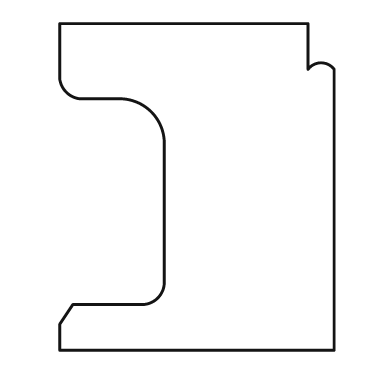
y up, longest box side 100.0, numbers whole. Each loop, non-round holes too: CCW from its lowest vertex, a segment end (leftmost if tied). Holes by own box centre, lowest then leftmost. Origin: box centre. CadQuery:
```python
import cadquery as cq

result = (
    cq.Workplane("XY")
    .moveTo(-42.0, -50.0)
    .lineTo(42.0, -50.0)
    .lineTo(42.0, 36.0)
    .threePointArc((38.0, 38.0), (34.0, 36.0))
    .lineTo(34.0, 50.0)
    .lineTo(-42.0, 50.0)
    .lineTo(-42.0, 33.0)
    .threePointArc((-40.0, 29.0), (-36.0, 27.0))
    .lineTo(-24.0, 27.0)
    .threePointArc((-14.0, 23.0), (-10.0, 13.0))
    .lineTo(-10.0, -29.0)
    .threePointArc((-12.0, -34.0), (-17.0, -36.0))
    .lineTo(-38.0, -36.0)
    .lineTo(-42.0, -42.0)
    .close()
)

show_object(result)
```